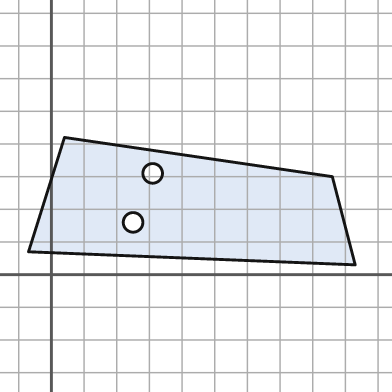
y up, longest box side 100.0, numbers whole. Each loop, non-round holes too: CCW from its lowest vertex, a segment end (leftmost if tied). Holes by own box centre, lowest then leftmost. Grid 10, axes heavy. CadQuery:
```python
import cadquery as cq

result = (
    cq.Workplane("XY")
    .moveTo(93.0, 3.0)
    .lineTo(86.0, 30.0)
    .lineTo(4.0, 42.0)
    .lineTo(-7.0, 7.0)
    .close()
    .moveTo(25.0, 16.0)
    .circle(3.0)
    .moveTo(31.0, 31.0)
    .circle(3.0)
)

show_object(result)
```